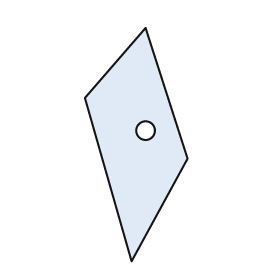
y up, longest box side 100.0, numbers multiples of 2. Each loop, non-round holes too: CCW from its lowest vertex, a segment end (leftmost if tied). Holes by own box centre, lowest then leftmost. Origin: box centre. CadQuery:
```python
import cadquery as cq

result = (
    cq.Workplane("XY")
    .moveTo(-2.0, -50.0)
    .lineTo(22.0, -6.0)
    .lineTo(4.0, 50.0)
    .lineTo(-22.0, 20.0)
    .close()
    .moveTo(4.0, 6.0)
    .circle(4.0)
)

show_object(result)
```